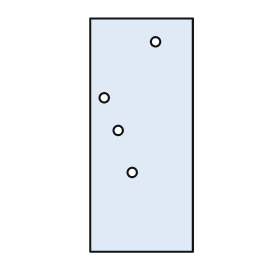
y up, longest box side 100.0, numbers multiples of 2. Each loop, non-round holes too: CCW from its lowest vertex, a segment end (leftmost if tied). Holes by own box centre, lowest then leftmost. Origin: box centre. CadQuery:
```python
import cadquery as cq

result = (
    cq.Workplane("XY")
    .moveTo(-22.0, -50.0)
    .lineTo(22.0, -50.0)
    .lineTo(22.0, 50.0)
    .lineTo(-22.0, 50.0)
    .close()
    .moveTo(-4.0, -16.0)
    .circle(2.0)
    .moveTo(-10.0, 2.0)
    .circle(2.0)
    .moveTo(-16.0, 16.0)
    .circle(2.0)
    .moveTo(6.0, 40.0)
    .circle(2.0)
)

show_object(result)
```